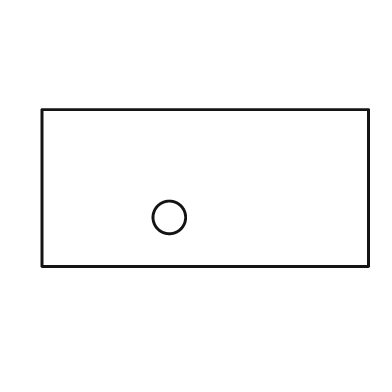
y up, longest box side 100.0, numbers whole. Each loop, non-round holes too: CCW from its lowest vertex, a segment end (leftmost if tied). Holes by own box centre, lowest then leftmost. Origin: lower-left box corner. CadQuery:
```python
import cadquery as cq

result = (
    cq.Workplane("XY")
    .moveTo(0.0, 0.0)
    .lineTo(100.0, 0.0)
    .lineTo(100.0, 48.0)
    .lineTo(0.0, 48.0)
    .close()
    .moveTo(39.0, 15.0)
    .circle(5.0)
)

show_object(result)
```